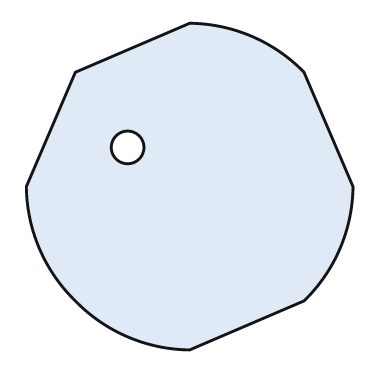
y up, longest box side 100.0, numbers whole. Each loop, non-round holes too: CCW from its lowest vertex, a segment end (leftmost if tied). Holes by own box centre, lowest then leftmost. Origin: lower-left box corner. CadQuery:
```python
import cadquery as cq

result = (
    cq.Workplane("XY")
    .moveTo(50.0, 0.0)
    .lineTo(85.0, 15.0)
    .threePointArc((96.0, 31.0), (100.0, 50.0))
    .lineTo(85.0, 85.0)
    .threePointArc((69.0, 96.0), (50.0, 100.0))
    .lineTo(15.0, 85.0)
    .lineTo(0.0, 50.0)
    .threePointArc((4.0, 31.0), (15.0, 15.0))
    .threePointArc((31.0, 4.0), (50.0, 0.0))
    .close()
    .moveTo(31.0, 62.0)
    .circle(5.0)
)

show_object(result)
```